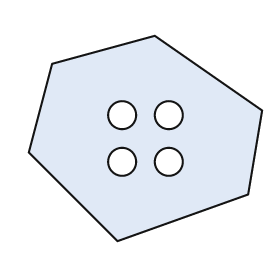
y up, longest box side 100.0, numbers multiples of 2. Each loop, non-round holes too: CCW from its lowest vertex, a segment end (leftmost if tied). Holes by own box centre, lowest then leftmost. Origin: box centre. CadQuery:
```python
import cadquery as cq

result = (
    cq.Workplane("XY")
    .moveTo(-12.0, -44.0)
    .lineTo(44.0, -24.0)
    .lineTo(50.0, 12.0)
    .lineTo(4.0, 44.0)
    .lineTo(-40.0, 32.0)
    .lineTo(-50.0, -6.0)
    .close()
    .moveTo(-10.0, -10.0)
    .circle(6.0)
    .moveTo(10.0, -10.0)
    .circle(6.0)
    .moveTo(-10.0, 10.0)
    .circle(6.0)
    .moveTo(10.0, 10.0)
    .circle(6.0)
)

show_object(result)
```